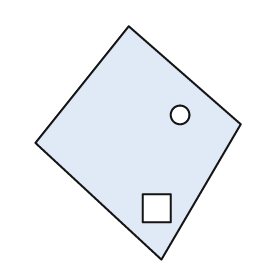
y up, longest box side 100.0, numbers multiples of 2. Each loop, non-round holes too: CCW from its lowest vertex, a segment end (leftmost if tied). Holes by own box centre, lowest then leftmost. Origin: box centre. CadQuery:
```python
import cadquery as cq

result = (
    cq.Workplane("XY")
    .moveTo(10.0, -50.0)
    .lineTo(44.0, 8.0)
    .lineTo(-4.0, 50.0)
    .lineTo(-44.0, 0.0)
    .close()
    .moveTo(2.0, -34.0)
    .lineTo(14.0, -34.0)
    .lineTo(14.0, -22.0)
    .lineTo(2.0, -22.0)
    .close()
    .moveTo(18.0, 12.0)
    .circle(4.0)
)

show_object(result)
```